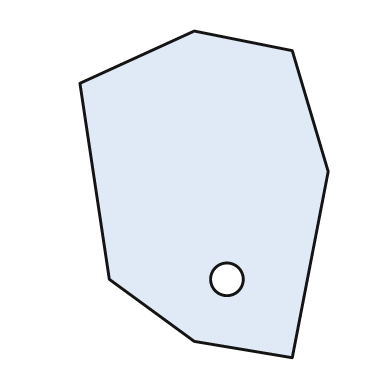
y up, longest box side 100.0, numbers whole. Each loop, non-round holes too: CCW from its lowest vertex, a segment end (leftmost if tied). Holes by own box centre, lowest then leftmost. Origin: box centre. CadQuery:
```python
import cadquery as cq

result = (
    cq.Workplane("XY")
    .moveTo(27.0, -50.0)
    .lineTo(38.0, 7.0)
    .lineTo(27.0, 44.0)
    .lineTo(-3.0, 50.0)
    .lineTo(-38.0, 34.0)
    .lineTo(-29.0, -26.0)
    .lineTo(-3.0, -45.0)
    .close()
    .moveTo(7.0, -26.0)
    .circle(5.0)
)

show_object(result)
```